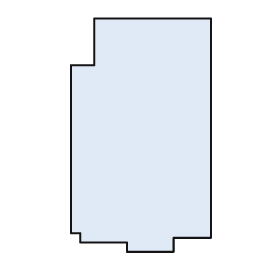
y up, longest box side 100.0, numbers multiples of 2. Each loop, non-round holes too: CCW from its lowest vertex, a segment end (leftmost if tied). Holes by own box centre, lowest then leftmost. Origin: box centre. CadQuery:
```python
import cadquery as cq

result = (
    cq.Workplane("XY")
    .moveTo(-6.0, -50.0)
    .lineTo(14.0, -50.0)
    .lineTo(14.0, -44.0)
    .lineTo(30.0, -44.0)
    .lineTo(30.0, 50.0)
    .lineTo(-20.0, 50.0)
    .lineTo(-20.0, 30.0)
    .lineTo(-30.0, 30.0)
    .lineTo(-30.0, -42.0)
    .lineTo(-26.0, -42.0)
    .lineTo(-26.0, -46.0)
    .lineTo(-6.0, -46.0)
    .close()
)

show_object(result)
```